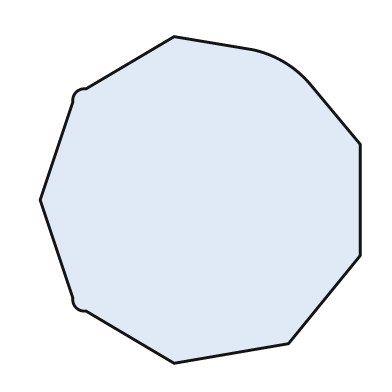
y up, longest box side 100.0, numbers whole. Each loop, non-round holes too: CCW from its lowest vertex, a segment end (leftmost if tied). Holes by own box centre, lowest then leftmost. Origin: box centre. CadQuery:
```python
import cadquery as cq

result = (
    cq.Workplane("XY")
    .moveTo(-8.0, -50.0)
    .lineTo(27.0, -44.0)
    .lineTo(49.0, -17.0)
    .lineTo(49.0, 17.0)
    .lineTo(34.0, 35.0)
    .threePointArc((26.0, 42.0), (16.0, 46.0))
    .lineTo(-8.0, 50.0)
    .lineTo(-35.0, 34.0)
    .threePointArc((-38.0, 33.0), (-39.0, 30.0))
    .lineTo(-49.0, 0.0)
    .lineTo(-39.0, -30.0)
    .threePointArc((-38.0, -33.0), (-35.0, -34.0))
    .close()
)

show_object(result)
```